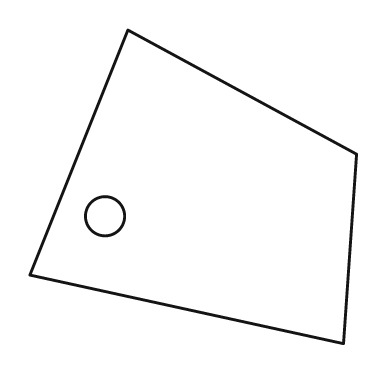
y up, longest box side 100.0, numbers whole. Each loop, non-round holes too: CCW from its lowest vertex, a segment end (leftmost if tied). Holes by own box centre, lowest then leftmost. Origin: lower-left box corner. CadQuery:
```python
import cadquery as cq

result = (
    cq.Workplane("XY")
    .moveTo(96.0, 0.0)
    .lineTo(100.0, 58.0)
    .lineTo(30.0, 96.0)
    .lineTo(0.0, 21.0)
    .close()
    .moveTo(23.0, 39.0)
    .circle(6.0)
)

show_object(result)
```